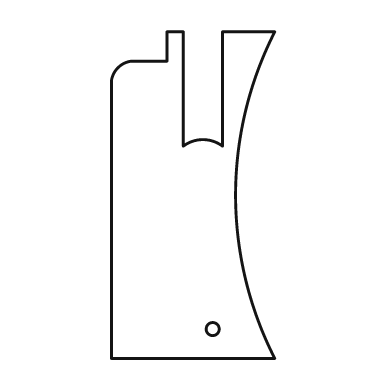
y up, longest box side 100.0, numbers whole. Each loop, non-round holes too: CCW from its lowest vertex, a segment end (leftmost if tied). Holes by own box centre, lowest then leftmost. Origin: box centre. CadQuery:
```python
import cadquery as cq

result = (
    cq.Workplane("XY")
    .moveTo(-25.0, -50.0)
    .lineTo(25.0, -50.0)
    .threePointArc((13.0, 0.0), (25.0, 50.0))
    .lineTo(9.0, 50.0)
    .lineTo(9.0, 15.0)
    .threePointArc((3.0, 17.0), (-3.0, 15.0))
    .lineTo(-3.0, 50.0)
    .lineTo(-8.0, 50.0)
    .lineTo(-8.0, 41.0)
    .lineTo(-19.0, 41.0)
    .threePointArc((-23.0, 39.0), (-25.0, 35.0))
    .close()
    .moveTo(6.0, -41.0)
    .circle(2.0)
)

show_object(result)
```